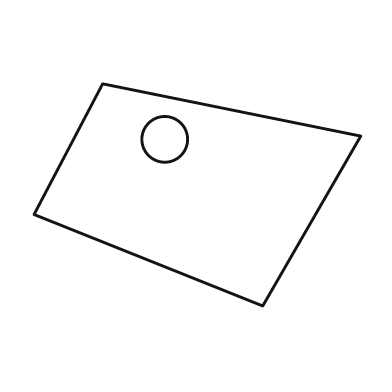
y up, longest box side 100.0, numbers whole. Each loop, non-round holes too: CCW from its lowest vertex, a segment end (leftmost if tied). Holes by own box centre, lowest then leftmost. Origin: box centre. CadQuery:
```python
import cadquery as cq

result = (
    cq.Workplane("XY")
    .moveTo(20.0, -34.0)
    .lineTo(50.0, 18.0)
    .lineTo(-29.0, 34.0)
    .lineTo(-50.0, -6.0)
    .close()
    .moveTo(-10.0, 17.0)
    .circle(7.0)
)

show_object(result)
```